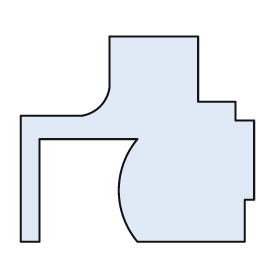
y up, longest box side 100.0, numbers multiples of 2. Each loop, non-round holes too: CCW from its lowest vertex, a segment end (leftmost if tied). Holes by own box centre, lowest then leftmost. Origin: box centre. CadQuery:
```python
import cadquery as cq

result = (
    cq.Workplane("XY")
    .moveTo(-50.0, -44.0)
    .lineTo(-42.0, -44.0)
    .lineTo(-42.0, 0.0)
    .lineTo(0.0, 0.0)
    .threePointArc((-8.0, -22.0), (0.0, -44.0))
    .lineTo(46.0, -44.0)
    .lineTo(46.0, -26.0)
    .lineTo(50.0, -26.0)
    .lineTo(50.0, 8.0)
    .lineTo(42.0, 8.0)
    .lineTo(42.0, 16.0)
    .lineTo(26.0, 16.0)
    .lineTo(26.0, 44.0)
    .lineTo(-12.0, 44.0)
    .lineTo(-12.0, 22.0)
    .threePointArc((-16.0, 14.0), (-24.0, 10.0))
    .lineTo(-50.0, 10.0)
    .close()
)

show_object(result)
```